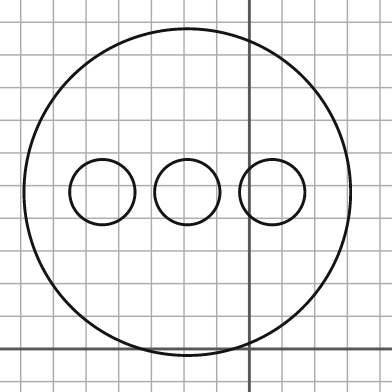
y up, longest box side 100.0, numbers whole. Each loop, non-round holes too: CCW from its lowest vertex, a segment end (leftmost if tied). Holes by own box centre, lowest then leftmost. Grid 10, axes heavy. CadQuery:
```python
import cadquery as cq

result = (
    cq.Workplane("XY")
    .moveTo(-19.0, 48.0)
    .circle(50.0)
    .moveTo(-45.0, 48.0)
    .circle(10.0)
    .moveTo(-19.0, 48.0)
    .circle(10.0)
    .moveTo(7.0, 48.0)
    .circle(10.0)
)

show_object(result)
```